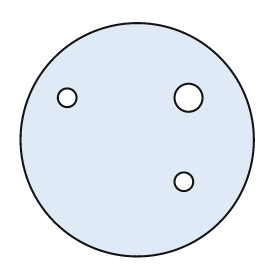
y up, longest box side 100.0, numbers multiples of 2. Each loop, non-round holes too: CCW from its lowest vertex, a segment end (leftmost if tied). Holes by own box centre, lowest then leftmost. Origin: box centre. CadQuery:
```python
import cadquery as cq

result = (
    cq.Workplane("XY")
    .moveTo(0.0, 0.0)
    .circle(50.0)
    .moveTo(20.0, -18.0)
    .circle(4.0)
    .moveTo(-30.0, 18.0)
    .circle(4.0)
    .moveTo(22.0, 18.0)
    .circle(6.0)
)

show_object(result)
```